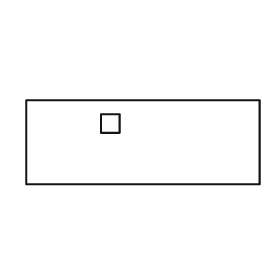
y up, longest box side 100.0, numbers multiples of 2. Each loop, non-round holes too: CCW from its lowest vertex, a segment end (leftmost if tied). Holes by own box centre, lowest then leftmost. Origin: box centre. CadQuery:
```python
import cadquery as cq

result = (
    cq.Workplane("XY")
    .moveTo(-50.0, -18.0)
    .lineTo(50.0, -18.0)
    .lineTo(50.0, 18.0)
    .lineTo(-50.0, 18.0)
    .close()
    .moveTo(-18.0, 4.0)
    .lineTo(-10.0, 4.0)
    .lineTo(-10.0, 12.0)
    .lineTo(-18.0, 12.0)
    .close()
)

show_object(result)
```